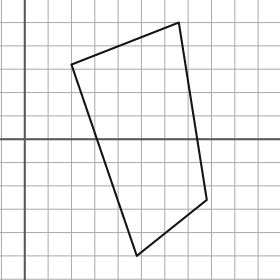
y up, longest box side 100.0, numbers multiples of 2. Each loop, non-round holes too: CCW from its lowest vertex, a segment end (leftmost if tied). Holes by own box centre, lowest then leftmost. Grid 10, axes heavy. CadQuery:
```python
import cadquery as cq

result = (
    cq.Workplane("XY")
    .moveTo(48.0, -50.0)
    .lineTo(78.0, -26.0)
    .lineTo(66.0, 50.0)
    .lineTo(20.0, 32.0)
    .close()
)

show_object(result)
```